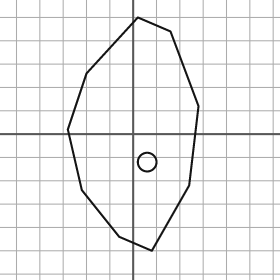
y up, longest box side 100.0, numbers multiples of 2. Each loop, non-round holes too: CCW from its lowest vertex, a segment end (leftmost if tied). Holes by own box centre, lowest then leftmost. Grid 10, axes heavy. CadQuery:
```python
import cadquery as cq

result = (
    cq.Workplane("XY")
    .moveTo(8.0, -50.0)
    .lineTo(24.0, -22.0)
    .lineTo(28.0, 12.0)
    .lineTo(16.0, 44.0)
    .lineTo(2.0, 50.0)
    .lineTo(-20.0, 26.0)
    .lineTo(-28.0, 2.0)
    .lineTo(-22.0, -24.0)
    .lineTo(-6.0, -44.0)
    .close()
    .moveTo(6.0, -12.0)
    .circle(4.0)
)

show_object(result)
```